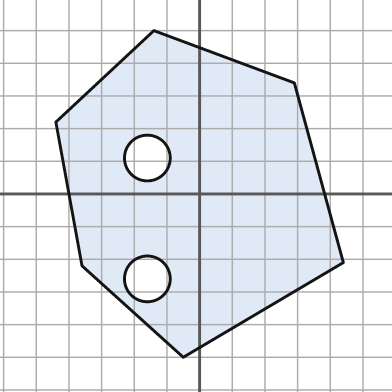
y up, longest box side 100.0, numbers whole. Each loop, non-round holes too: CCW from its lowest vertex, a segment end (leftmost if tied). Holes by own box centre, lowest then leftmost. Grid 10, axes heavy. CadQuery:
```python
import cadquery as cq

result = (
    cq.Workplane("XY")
    .moveTo(-5.0, -50.0)
    .lineTo(44.0, -21.0)
    .lineTo(29.0, 34.0)
    .lineTo(-14.0, 50.0)
    .lineTo(-44.0, 22.0)
    .lineTo(-36.0, -22.0)
    .close()
    .moveTo(-16.0, -26.0)
    .circle(7.0)
    .moveTo(-16.0, 11.0)
    .circle(7.0)
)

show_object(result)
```